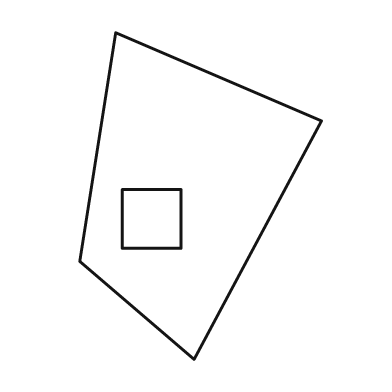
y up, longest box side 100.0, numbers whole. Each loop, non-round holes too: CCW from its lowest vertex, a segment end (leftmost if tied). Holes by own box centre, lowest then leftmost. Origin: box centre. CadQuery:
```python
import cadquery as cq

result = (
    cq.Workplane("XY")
    .moveTo(-2.0, -50.0)
    .lineTo(37.0, 23.0)
    .lineTo(-26.0, 50.0)
    .lineTo(-37.0, -20.0)
    .close()
    .moveTo(-24.0, -16.0)
    .lineTo(-6.0, -16.0)
    .lineTo(-6.0, 2.0)
    .lineTo(-24.0, 2.0)
    .close()
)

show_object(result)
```